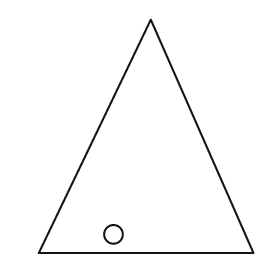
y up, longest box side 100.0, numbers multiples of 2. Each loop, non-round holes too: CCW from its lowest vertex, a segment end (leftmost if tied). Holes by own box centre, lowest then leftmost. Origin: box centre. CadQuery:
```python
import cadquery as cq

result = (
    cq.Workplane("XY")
    .moveTo(-46.0, -50.0)
    .lineTo(46.0, -50.0)
    .lineTo(2.0, 50.0)
    .close()
    .moveTo(-14.0, -42.0)
    .circle(4.0)
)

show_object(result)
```